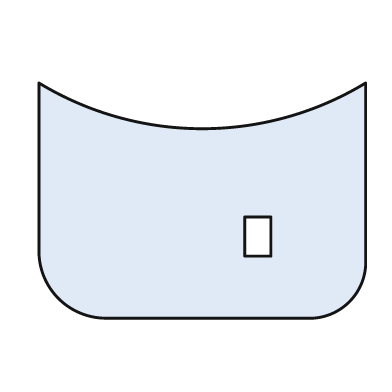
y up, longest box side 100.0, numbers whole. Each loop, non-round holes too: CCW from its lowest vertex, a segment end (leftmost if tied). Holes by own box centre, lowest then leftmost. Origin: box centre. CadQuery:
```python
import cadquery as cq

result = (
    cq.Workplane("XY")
    .moveTo(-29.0, -36.0)
    .lineTo(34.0, -36.0)
    .threePointArc((45.0, -31.0), (50.0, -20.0))
    .lineTo(50.0, 36.0)
    .threePointArc((0.0, 22.0), (-50.0, 36.0))
    .lineTo(-50.0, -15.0)
    .threePointArc((-44.0, -30.0), (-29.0, -36.0))
    .close()
    .moveTo(13.0, -17.0)
    .lineTo(21.0, -17.0)
    .lineTo(21.0, -5.0)
    .lineTo(13.0, -5.0)
    .close()
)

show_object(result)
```